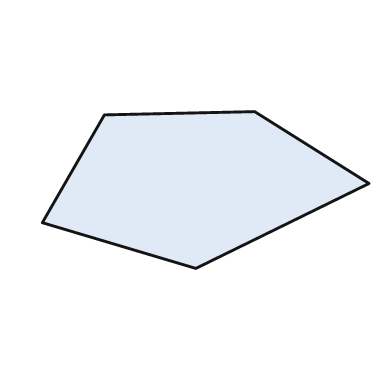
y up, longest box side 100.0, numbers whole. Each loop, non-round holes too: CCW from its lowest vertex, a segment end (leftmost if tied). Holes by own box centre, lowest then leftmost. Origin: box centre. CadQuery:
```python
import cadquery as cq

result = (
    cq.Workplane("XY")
    .moveTo(-3.0, -24.0)
    .lineTo(50.0, 2.0)
    .lineTo(15.0, 24.0)
    .lineTo(-31.0, 23.0)
    .lineTo(-50.0, -10.0)
    .close()
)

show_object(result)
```